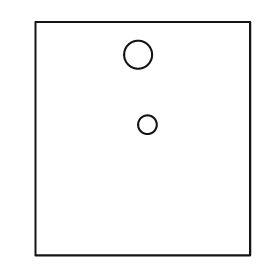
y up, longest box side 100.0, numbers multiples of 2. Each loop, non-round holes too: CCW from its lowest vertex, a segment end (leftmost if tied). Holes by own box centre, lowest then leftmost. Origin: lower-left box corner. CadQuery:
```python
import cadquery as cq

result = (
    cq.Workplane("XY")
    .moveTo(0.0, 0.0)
    .lineTo(92.0, 0.0)
    .lineTo(92.0, 100.0)
    .lineTo(0.0, 100.0)
    .close()
    .moveTo(48.0, 56.0)
    .circle(4.0)
    .moveTo(44.0, 86.0)
    .circle(6.0)
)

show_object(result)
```